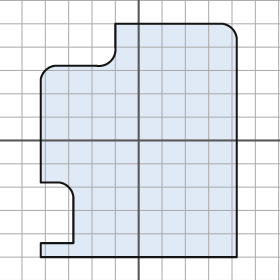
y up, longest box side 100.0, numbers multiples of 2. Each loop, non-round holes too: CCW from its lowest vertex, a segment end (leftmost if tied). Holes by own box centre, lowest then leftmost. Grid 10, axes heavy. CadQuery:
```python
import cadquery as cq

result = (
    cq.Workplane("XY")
    .moveTo(-42.0, -50.0)
    .lineTo(42.0, -50.0)
    .lineTo(42.0, 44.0)
    .threePointArc((40.0, 48.0), (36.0, 50.0))
    .lineTo(-10.0, 50.0)
    .lineTo(-10.0, 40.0)
    .threePointArc((-12.0, 34.0), (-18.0, 32.0))
    .lineTo(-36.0, 32.0)
    .threePointArc((-40.0, 30.0), (-42.0, 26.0))
    .lineTo(-42.0, -18.0)
    .lineTo(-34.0, -18.0)
    .threePointArc((-30.0, -20.0), (-28.0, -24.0))
    .lineTo(-28.0, -44.0)
    .lineTo(-42.0, -44.0)
    .close()
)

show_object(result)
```